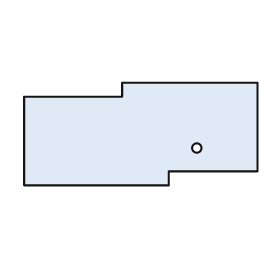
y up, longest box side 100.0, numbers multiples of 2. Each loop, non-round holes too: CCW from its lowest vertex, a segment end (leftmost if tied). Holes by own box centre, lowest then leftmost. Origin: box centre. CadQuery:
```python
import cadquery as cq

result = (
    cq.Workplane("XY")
    .moveTo(-50.0, -22.0)
    .lineTo(12.0, -22.0)
    .lineTo(12.0, -16.0)
    .lineTo(50.0, -16.0)
    .lineTo(50.0, 22.0)
    .lineTo(-8.0, 22.0)
    .lineTo(-8.0, 16.0)
    .lineTo(-50.0, 16.0)
    .close()
    .moveTo(24.0, -6.0)
    .circle(2.0)
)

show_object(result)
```